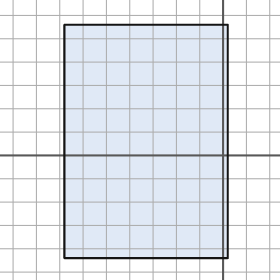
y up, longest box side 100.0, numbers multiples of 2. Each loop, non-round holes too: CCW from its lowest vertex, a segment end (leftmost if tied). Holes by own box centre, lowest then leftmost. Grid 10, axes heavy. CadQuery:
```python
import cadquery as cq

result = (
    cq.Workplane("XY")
    .moveTo(-68.0, -44.0)
    .lineTo(2.0, -44.0)
    .lineTo(2.0, 56.0)
    .lineTo(-68.0, 56.0)
    .close()
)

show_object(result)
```